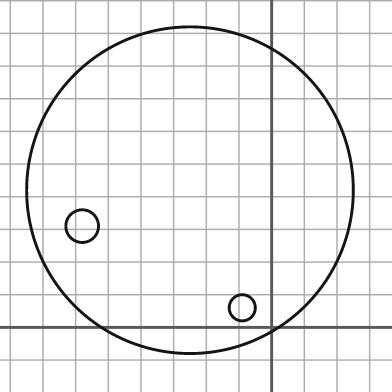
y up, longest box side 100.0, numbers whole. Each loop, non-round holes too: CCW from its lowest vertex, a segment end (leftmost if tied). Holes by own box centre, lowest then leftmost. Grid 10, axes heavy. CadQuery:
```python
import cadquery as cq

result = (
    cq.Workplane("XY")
    .moveTo(-25.0, 42.0)
    .circle(50.0)
    .moveTo(-9.0, 6.0)
    .circle(4.0)
    .moveTo(-58.0, 31.0)
    .circle(5.0)
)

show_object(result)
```